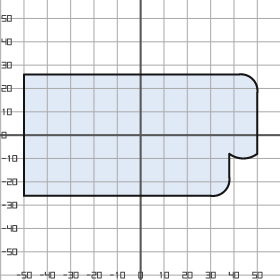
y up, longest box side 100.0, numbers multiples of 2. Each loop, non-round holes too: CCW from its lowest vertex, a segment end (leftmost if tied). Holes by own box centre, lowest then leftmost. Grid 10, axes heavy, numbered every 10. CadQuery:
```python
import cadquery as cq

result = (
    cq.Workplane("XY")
    .moveTo(-50.0, -26.0)
    .lineTo(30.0, -26.0)
    .threePointArc((36.0, -24.0), (38.0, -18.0))
    .lineTo(38.0, -8.0)
    .threePointArc((44.0, -10.0), (50.0, -8.0))
    .lineTo(50.0, 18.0)
    .threePointArc((48.0, 24.0), (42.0, 26.0))
    .lineTo(-50.0, 26.0)
    .close()
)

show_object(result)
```